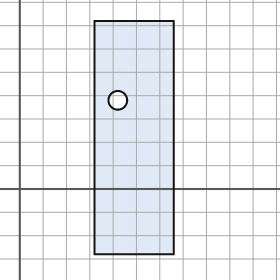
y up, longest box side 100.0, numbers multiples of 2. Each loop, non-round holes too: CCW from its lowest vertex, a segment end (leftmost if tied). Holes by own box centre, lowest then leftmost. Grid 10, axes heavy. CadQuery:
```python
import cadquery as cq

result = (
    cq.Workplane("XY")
    .moveTo(32.0, -28.0)
    .lineTo(66.0, -28.0)
    .lineTo(66.0, 72.0)
    .lineTo(32.0, 72.0)
    .close()
    .moveTo(42.0, 38.0)
    .circle(4.0)
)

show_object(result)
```